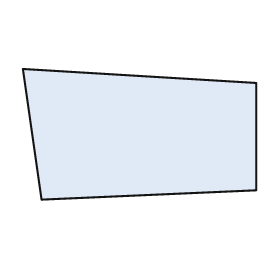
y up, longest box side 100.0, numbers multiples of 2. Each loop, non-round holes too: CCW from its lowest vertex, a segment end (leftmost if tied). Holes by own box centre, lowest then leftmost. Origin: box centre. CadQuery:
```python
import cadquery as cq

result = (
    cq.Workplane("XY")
    .moveTo(-42.0, -28.0)
    .lineTo(50.0, -24.0)
    .lineTo(50.0, 22.0)
    .lineTo(-50.0, 28.0)
    .close()
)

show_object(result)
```